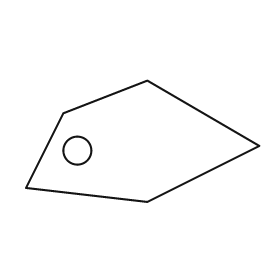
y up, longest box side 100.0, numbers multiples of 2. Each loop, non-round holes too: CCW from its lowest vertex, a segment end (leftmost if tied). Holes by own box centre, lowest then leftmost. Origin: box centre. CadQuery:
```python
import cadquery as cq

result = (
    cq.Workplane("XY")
    .moveTo(2.0, -26.0)
    .lineTo(50.0, -2.0)
    .lineTo(2.0, 26.0)
    .lineTo(-34.0, 12.0)
    .lineTo(-50.0, -20.0)
    .close()
    .moveTo(-28.0, -4.0)
    .circle(6.0)
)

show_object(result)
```